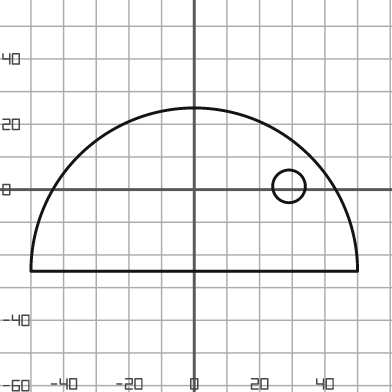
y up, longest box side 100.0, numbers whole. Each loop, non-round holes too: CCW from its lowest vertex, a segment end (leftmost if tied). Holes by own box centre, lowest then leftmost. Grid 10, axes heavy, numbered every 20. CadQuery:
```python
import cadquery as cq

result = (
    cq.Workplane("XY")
    .moveTo(-50.0, -25.0)
    .lineTo(50.0, -25.0)
    .threePointArc((0.0, 25.0), (-50.0, -25.0))
    .close()
    .moveTo(29.0, 1.0)
    .circle(5.0)
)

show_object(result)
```